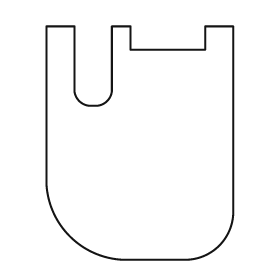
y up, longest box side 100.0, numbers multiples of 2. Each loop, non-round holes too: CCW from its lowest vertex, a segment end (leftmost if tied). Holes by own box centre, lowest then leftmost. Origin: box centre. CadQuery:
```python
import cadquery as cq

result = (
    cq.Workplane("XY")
    .moveTo(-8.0, -50.0)
    .lineTo(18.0, -50.0)
    .threePointArc((34.0, -44.0), (40.0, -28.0))
    .lineTo(40.0, 50.0)
    .lineTo(28.0, 50.0)
    .lineTo(28.0, 40.0)
    .lineTo(-4.0, 40.0)
    .lineTo(-4.0, 50.0)
    .lineTo(-12.0, 50.0)
    .lineTo(-12.0, 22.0)
    .threePointArc((-14.0, 18.0), (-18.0, 16.0))
    .lineTo(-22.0, 16.0)
    .threePointArc((-26.0, 18.0), (-28.0, 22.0))
    .lineTo(-28.0, 50.0)
    .lineTo(-40.0, 50.0)
    .lineTo(-40.0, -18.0)
    .threePointArc((-30.0, -40.0), (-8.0, -50.0))
    .close()
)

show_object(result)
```